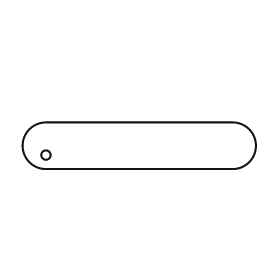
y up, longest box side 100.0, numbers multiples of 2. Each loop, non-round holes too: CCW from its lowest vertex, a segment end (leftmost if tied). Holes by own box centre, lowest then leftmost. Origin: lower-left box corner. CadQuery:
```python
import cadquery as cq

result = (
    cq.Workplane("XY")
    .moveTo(10.0, 0.0)
    .lineTo(90.0, 0.0)
    .threePointArc((100.0, 10.0), (90.0, 20.0))
    .lineTo(10.0, 20.0)
    .threePointArc((0.0, 10.0), (10.0, 0.0))
    .close()
    .moveTo(10.0, 6.0)
    .circle(2.0)
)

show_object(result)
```